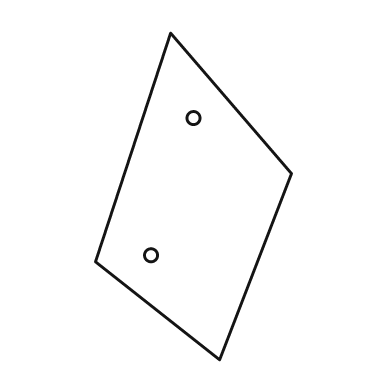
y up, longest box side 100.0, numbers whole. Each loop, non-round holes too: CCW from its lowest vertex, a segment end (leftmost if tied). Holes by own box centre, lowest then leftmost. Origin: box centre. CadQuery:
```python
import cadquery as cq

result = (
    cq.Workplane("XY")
    .moveTo(8.0, -50.0)
    .lineTo(30.0, 7.0)
    .lineTo(-7.0, 50.0)
    .lineTo(-30.0, -20.0)
    .close()
    .moveTo(-13.0, -18.0)
    .circle(2.0)
    .moveTo(0.0, 24.0)
    .circle(2.0)
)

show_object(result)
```